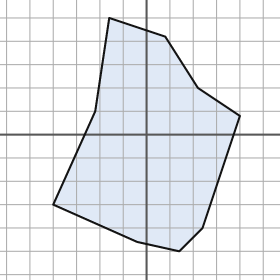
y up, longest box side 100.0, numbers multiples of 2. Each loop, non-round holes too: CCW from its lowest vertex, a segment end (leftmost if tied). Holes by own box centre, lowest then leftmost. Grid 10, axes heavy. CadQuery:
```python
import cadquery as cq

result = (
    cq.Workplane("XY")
    .moveTo(14.0, -50.0)
    .lineTo(24.0, -40.0)
    .lineTo(40.0, 8.0)
    .lineTo(22.0, 20.0)
    .lineTo(8.0, 42.0)
    .lineTo(-16.0, 50.0)
    .lineTo(-22.0, 10.0)
    .lineTo(-40.0, -30.0)
    .lineTo(-4.0, -46.0)
    .close()
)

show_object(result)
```